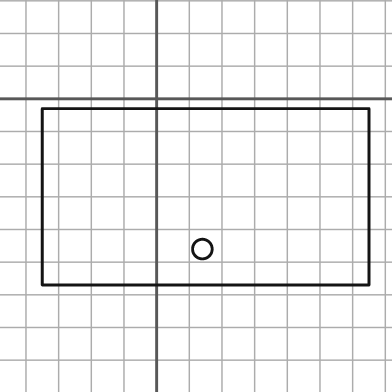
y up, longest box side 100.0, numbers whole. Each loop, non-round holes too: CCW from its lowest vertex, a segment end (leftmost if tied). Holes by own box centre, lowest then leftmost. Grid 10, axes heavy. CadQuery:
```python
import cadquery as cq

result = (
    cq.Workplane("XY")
    .moveTo(-35.0, -57.0)
    .lineTo(65.0, -57.0)
    .lineTo(65.0, -3.0)
    .lineTo(-35.0, -3.0)
    .close()
    .moveTo(14.0, -46.0)
    .circle(3.0)
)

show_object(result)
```